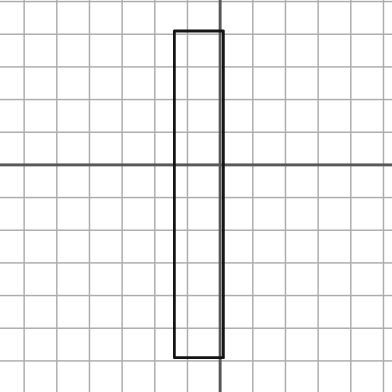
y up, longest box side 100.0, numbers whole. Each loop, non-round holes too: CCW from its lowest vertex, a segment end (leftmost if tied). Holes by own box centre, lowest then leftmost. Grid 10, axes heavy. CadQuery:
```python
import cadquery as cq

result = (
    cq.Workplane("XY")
    .moveTo(-14.0, -59.0)
    .lineTo(1.0, -59.0)
    .lineTo(1.0, 41.0)
    .lineTo(-14.0, 41.0)
    .close()
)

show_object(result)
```